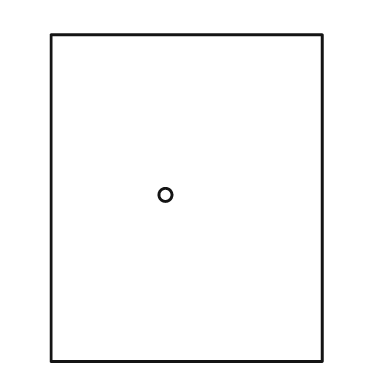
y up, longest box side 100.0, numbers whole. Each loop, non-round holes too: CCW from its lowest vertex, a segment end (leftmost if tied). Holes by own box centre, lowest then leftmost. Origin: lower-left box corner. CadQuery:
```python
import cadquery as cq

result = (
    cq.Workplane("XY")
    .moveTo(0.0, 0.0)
    .lineTo(83.0, 0.0)
    .lineTo(83.0, 100.0)
    .lineTo(0.0, 100.0)
    .close()
    .moveTo(35.0, 51.0)
    .circle(2.0)
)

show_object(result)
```